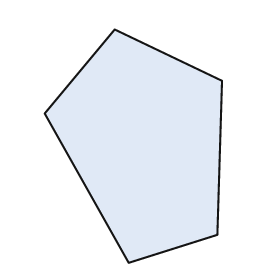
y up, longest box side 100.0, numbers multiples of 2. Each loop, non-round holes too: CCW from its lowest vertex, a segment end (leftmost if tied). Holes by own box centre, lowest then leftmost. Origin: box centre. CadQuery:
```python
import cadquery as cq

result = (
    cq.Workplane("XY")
    .moveTo(-2.0, -50.0)
    .lineTo(36.0, -38.0)
    .lineTo(38.0, 28.0)
    .lineTo(-8.0, 50.0)
    .lineTo(-38.0, 14.0)
    .close()
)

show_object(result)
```